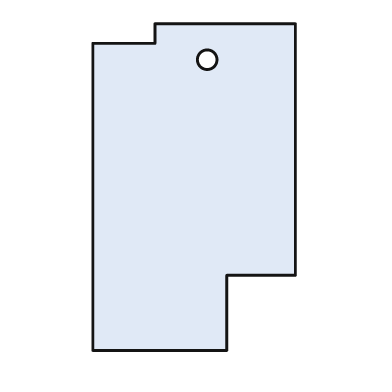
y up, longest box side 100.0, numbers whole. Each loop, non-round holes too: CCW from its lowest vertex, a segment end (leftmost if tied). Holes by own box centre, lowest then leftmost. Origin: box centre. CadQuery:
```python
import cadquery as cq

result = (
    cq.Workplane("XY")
    .moveTo(-31.0, -50.0)
    .lineTo(10.0, -50.0)
    .lineTo(10.0, -27.0)
    .lineTo(31.0, -27.0)
    .lineTo(31.0, 50.0)
    .lineTo(-12.0, 50.0)
    .lineTo(-12.0, 44.0)
    .lineTo(-31.0, 44.0)
    .close()
    .moveTo(4.0, 39.0)
    .circle(3.0)
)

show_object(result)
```